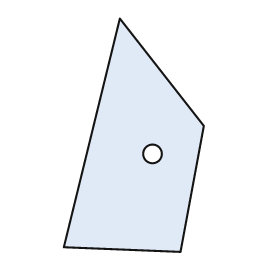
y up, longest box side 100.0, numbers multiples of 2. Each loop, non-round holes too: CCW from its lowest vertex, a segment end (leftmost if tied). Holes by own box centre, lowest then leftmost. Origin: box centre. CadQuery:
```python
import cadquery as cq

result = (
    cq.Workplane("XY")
    .moveTo(20.0, -50.0)
    .lineTo(30.0, 4.0)
    .lineTo(-6.0, 50.0)
    .lineTo(-30.0, -48.0)
    .close()
    .moveTo(8.0, -8.0)
    .circle(4.0)
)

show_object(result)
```